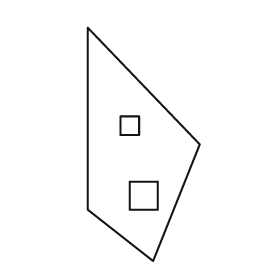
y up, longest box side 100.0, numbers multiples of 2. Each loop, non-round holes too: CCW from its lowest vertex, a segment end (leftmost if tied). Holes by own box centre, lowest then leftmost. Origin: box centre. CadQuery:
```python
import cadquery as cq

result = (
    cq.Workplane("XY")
    .moveTo(4.0, -50.0)
    .lineTo(24.0, 0.0)
    .lineTo(-24.0, 50.0)
    .lineTo(-24.0, -28.0)
    .close()
    .moveTo(-6.0, -28.0)
    .lineTo(6.0, -28.0)
    .lineTo(6.0, -16.0)
    .lineTo(-6.0, -16.0)
    .close()
    .moveTo(-10.0, 4.0)
    .lineTo(-2.0, 4.0)
    .lineTo(-2.0, 12.0)
    .lineTo(-10.0, 12.0)
    .close()
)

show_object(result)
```